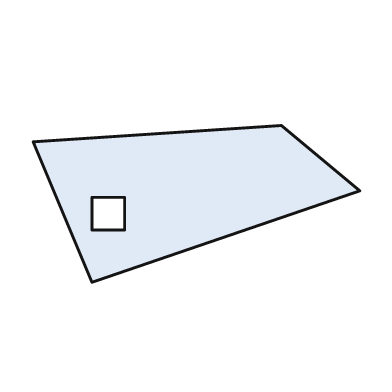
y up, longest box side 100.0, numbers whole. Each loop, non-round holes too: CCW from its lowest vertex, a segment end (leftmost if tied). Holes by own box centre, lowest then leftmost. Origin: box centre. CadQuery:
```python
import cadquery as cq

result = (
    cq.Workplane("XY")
    .moveTo(-32.0, -24.0)
    .lineTo(50.0, 4.0)
    .lineTo(26.0, 24.0)
    .lineTo(-50.0, 19.0)
    .close()
    .moveTo(-32.0, -8.0)
    .lineTo(-22.0, -8.0)
    .lineTo(-22.0, 2.0)
    .lineTo(-32.0, 2.0)
    .close()
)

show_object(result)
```